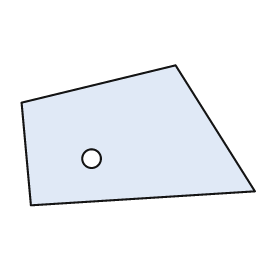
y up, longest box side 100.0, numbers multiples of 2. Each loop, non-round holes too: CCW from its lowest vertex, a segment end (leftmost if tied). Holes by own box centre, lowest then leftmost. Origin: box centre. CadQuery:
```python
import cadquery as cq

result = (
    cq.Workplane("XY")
    .moveTo(-46.0, -30.0)
    .lineTo(50.0, -24.0)
    .lineTo(16.0, 30.0)
    .lineTo(-50.0, 14.0)
    .close()
    .moveTo(-20.0, -10.0)
    .circle(4.0)
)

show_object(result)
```